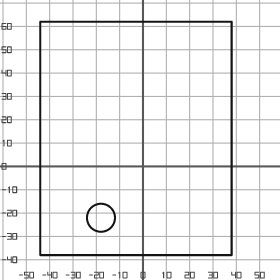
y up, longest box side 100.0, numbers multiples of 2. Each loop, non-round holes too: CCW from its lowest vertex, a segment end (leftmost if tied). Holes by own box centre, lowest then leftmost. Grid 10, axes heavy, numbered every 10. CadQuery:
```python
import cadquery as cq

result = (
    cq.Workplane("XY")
    .moveTo(-44.0, -38.0)
    .lineTo(38.0, -38.0)
    .lineTo(38.0, 62.0)
    .lineTo(-44.0, 62.0)
    .close()
    .moveTo(-18.0, -22.0)
    .circle(6.0)
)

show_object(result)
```